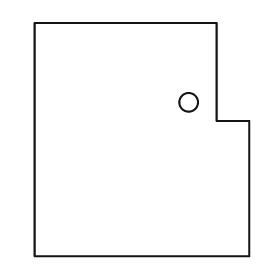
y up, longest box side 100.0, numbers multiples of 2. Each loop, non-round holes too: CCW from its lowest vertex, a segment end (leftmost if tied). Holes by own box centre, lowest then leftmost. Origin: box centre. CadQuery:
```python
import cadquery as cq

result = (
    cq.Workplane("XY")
    .moveTo(-46.0, -50.0)
    .lineTo(46.0, -50.0)
    .lineTo(46.0, 8.0)
    .lineTo(32.0, 8.0)
    .lineTo(32.0, 50.0)
    .lineTo(-46.0, 50.0)
    .close()
    .moveTo(20.0, 16.0)
    .circle(4.0)
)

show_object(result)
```